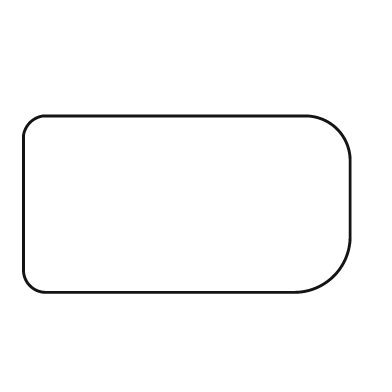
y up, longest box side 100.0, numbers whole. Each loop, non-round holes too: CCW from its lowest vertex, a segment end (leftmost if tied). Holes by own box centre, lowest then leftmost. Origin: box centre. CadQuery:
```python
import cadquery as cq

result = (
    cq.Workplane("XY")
    .moveTo(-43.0, -27.0)
    .lineTo(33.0, -27.0)
    .threePointArc((45.0, -22.0), (50.0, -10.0))
    .lineTo(50.0, 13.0)
    .threePointArc((46.0, 23.0), (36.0, 27.0))
    .lineTo(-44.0, 27.0)
    .threePointArc((-48.0, 25.0), (-50.0, 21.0))
    .lineTo(-50.0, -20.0)
    .threePointArc((-48.0, -25.0), (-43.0, -27.0))
    .close()
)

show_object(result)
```